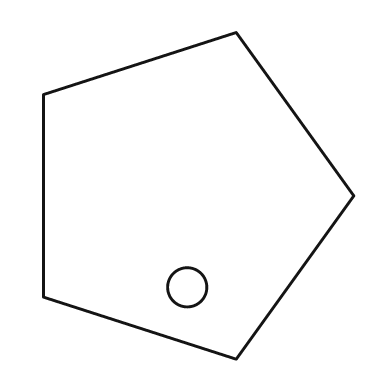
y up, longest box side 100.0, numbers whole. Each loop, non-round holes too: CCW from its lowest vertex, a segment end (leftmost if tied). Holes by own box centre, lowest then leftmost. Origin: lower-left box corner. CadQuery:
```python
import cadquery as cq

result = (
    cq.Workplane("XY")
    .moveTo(59.0, 0.0)
    .lineTo(95.0, 50.0)
    .lineTo(59.0, 100.0)
    .lineTo(0.0, 81.0)
    .lineTo(0.0, 19.0)
    .close()
    .moveTo(44.0, 22.0)
    .circle(6.0)
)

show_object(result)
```